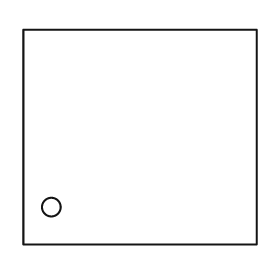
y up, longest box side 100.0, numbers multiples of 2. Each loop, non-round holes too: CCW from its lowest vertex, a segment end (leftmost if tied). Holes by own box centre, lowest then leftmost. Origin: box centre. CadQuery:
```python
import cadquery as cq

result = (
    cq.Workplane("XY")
    .moveTo(-50.0, -46.0)
    .lineTo(50.0, -46.0)
    .lineTo(50.0, 46.0)
    .lineTo(-50.0, 46.0)
    .close()
    .moveTo(-38.0, -30.0)
    .circle(4.0)
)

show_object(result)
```